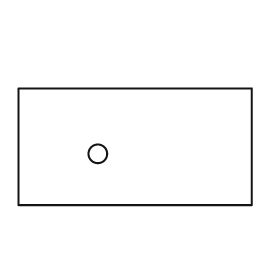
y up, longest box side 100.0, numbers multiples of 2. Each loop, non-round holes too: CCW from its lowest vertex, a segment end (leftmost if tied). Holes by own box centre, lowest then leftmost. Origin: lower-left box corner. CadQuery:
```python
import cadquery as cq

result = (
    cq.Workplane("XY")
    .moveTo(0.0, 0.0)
    .lineTo(100.0, 0.0)
    .lineTo(100.0, 50.0)
    .lineTo(0.0, 50.0)
    .close()
    .moveTo(34.0, 22.0)
    .circle(4.0)
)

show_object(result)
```